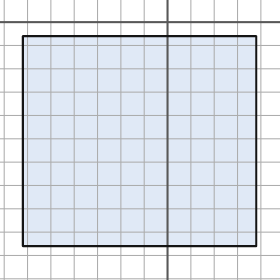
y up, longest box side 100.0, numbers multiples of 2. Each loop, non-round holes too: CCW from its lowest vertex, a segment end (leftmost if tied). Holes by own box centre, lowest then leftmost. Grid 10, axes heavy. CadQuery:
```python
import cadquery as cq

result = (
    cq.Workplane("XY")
    .moveTo(-62.0, -96.0)
    .lineTo(38.0, -96.0)
    .lineTo(38.0, -6.0)
    .lineTo(-62.0, -6.0)
    .close()
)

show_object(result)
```